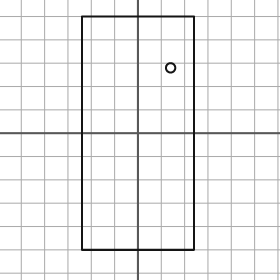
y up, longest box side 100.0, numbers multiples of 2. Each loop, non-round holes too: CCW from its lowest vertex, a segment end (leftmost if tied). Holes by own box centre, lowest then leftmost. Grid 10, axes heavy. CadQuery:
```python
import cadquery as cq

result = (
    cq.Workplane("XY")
    .moveTo(-24.0, -50.0)
    .lineTo(24.0, -50.0)
    .lineTo(24.0, 50.0)
    .lineTo(-24.0, 50.0)
    .close()
    .moveTo(14.0, 28.0)
    .circle(2.0)
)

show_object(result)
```